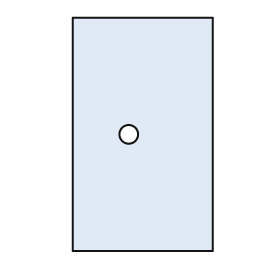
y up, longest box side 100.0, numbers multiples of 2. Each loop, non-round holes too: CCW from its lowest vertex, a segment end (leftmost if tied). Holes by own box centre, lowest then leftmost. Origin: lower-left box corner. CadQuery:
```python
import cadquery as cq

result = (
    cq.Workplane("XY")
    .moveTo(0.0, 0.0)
    .lineTo(60.0, 0.0)
    .lineTo(60.0, 100.0)
    .lineTo(0.0, 100.0)
    .close()
    .moveTo(24.0, 50.0)
    .circle(4.0)
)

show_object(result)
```